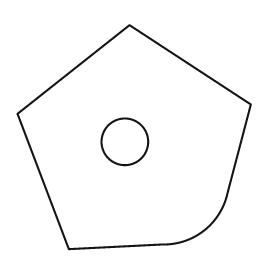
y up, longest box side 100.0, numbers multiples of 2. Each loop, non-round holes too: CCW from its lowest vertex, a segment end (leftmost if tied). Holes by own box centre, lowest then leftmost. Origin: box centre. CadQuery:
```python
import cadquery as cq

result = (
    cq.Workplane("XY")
    .moveTo(-28.0, -48.0)
    .lineTo(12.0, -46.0)
    .threePointArc((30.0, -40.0), (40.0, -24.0))
    .lineTo(50.0, 14.0)
    .lineTo(-2.0, 48.0)
    .lineTo(-50.0, 10.0)
    .close()
    .moveTo(-4.0, -2.0)
    .circle(10.0)
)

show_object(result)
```